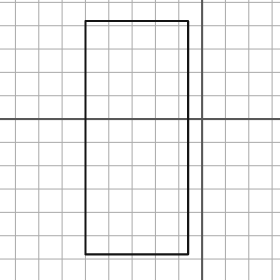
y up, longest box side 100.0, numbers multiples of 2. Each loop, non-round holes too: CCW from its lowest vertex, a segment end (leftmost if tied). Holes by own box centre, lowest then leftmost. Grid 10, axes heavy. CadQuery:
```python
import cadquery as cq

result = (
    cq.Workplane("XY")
    .moveTo(-50.0, -58.0)
    .lineTo(-6.0, -58.0)
    .lineTo(-6.0, 42.0)
    .lineTo(-50.0, 42.0)
    .close()
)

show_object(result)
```